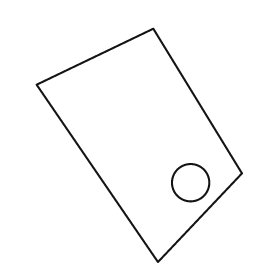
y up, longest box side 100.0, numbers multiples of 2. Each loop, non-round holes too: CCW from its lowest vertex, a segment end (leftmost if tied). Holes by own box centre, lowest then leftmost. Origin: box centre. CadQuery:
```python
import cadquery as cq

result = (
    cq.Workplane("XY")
    .moveTo(8.0, -50.0)
    .lineTo(44.0, -12.0)
    .lineTo(6.0, 50.0)
    .lineTo(-44.0, 26.0)
    .close()
    .moveTo(22.0, -16.0)
    .circle(8.0)
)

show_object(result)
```